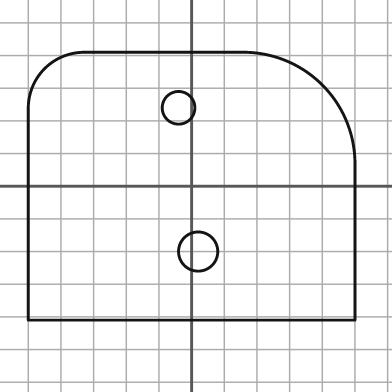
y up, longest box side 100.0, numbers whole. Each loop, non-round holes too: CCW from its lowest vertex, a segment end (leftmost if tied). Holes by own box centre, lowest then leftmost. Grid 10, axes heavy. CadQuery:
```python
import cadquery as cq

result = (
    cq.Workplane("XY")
    .moveTo(-50.0, -41.0)
    .lineTo(50.0, -41.0)
    .lineTo(50.0, 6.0)
    .threePointArc((40.0, 31.0), (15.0, 41.0))
    .lineTo(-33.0, 41.0)
    .threePointArc((-45.0, 36.0), (-50.0, 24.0))
    .close()
    .moveTo(2.0, -20.0)
    .circle(6.0)
    .moveTo(-4.0, 24.0)
    .circle(5.0)
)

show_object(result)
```